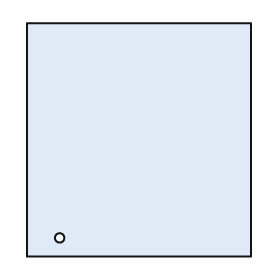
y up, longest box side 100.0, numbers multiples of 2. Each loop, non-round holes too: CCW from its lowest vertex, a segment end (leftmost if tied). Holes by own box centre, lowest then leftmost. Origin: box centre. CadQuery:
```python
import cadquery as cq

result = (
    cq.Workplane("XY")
    .moveTo(-48.0, -50.0)
    .lineTo(48.0, -50.0)
    .lineTo(48.0, 50.0)
    .lineTo(-48.0, 50.0)
    .close()
    .moveTo(-34.0, -42.0)
    .circle(2.0)
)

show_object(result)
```